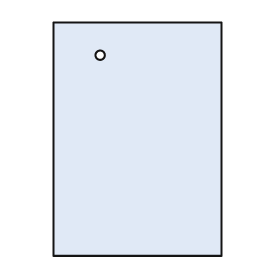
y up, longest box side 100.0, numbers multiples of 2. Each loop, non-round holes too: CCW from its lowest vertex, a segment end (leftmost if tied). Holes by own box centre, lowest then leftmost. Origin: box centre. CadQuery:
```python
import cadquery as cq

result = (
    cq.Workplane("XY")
    .moveTo(-36.0, -50.0)
    .lineTo(36.0, -50.0)
    .lineTo(36.0, 50.0)
    .lineTo(-36.0, 50.0)
    .close()
    .moveTo(-16.0, 36.0)
    .circle(2.0)
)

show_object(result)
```